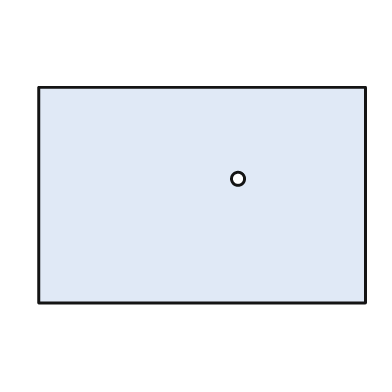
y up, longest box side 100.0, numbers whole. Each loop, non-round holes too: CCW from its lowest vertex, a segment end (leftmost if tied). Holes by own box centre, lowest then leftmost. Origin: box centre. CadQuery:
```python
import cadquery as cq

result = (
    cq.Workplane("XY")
    .moveTo(-50.0, -33.0)
    .lineTo(50.0, -33.0)
    .lineTo(50.0, 33.0)
    .lineTo(-50.0, 33.0)
    .close()
    .moveTo(11.0, 5.0)
    .circle(2.0)
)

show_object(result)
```